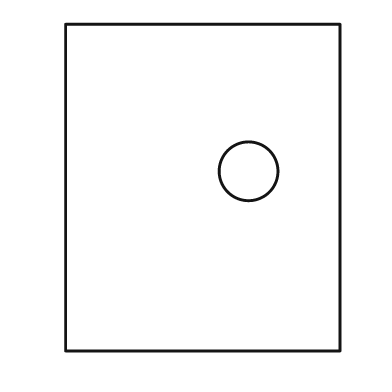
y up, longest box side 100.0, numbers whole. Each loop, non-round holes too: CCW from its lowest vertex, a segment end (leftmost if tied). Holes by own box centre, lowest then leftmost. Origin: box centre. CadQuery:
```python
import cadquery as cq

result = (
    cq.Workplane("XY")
    .moveTo(-42.0, -50.0)
    .lineTo(42.0, -50.0)
    .lineTo(42.0, 50.0)
    .lineTo(-42.0, 50.0)
    .close()
    .moveTo(14.0, 5.0)
    .circle(9.0)
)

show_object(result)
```